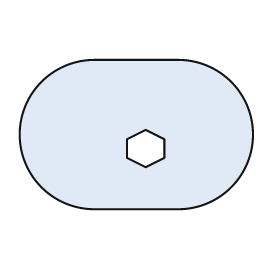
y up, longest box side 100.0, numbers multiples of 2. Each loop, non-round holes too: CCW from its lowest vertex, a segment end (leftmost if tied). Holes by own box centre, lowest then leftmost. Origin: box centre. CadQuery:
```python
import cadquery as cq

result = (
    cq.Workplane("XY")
    .moveTo(-18.0, -32.0)
    .lineTo(18.0, -32.0)
    .threePointArc((50.0, 0.0), (18.0, 32.0))
    .lineTo(-18.0, 32.0)
    .threePointArc((-50.0, 0.0), (-18.0, -32.0))
    .close()
    .moveTo(4.0, -14.0)
    .lineTo(12.0, -10.0)
    .lineTo(12.0, -2.0)
    .lineTo(4.0, 2.0)
    .lineTo(-4.0, -2.0)
    .lineTo(-4.0, -10.0)
    .close()
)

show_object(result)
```